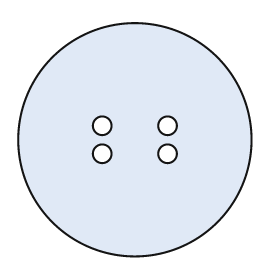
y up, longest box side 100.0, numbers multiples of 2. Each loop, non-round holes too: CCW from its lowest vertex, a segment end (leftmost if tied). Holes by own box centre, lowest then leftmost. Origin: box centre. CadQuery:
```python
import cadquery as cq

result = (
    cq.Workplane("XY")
    .moveTo(0.0, 0.0)
    .circle(50.0)
    .moveTo(-14.0, -6.0)
    .circle(4.0)
    .moveTo(14.0, -6.0)
    .circle(4.0)
    .moveTo(-14.0, 6.0)
    .circle(4.0)
    .moveTo(14.0, 6.0)
    .circle(4.0)
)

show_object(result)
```